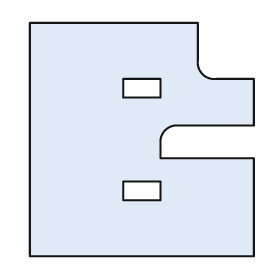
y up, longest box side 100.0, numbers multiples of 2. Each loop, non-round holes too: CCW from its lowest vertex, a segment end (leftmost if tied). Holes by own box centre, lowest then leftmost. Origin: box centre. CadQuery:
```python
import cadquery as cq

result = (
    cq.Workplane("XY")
    .moveTo(-48.0, -50.0)
    .lineTo(48.0, -50.0)
    .lineTo(48.0, -8.0)
    .lineTo(8.0, -8.0)
    .lineTo(8.0, 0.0)
    .threePointArc((10.0, 4.0), (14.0, 6.0))
    .lineTo(48.0, 6.0)
    .lineTo(48.0, 26.0)
    .lineTo(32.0, 26.0)
    .threePointArc((26.0, 28.0), (24.0, 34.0))
    .lineTo(24.0, 50.0)
    .lineTo(-48.0, 50.0)
    .close()
    .moveTo(-8.0, -26.0)
    .lineTo(8.0, -26.0)
    .lineTo(8.0, -18.0)
    .lineTo(-8.0, -18.0)
    .close()
    .moveTo(-8.0, 18.0)
    .lineTo(8.0, 18.0)
    .lineTo(8.0, 26.0)
    .lineTo(-8.0, 26.0)
    .close()
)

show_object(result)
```